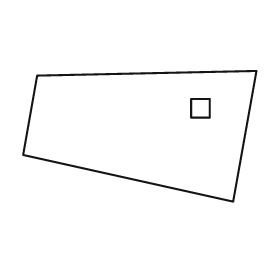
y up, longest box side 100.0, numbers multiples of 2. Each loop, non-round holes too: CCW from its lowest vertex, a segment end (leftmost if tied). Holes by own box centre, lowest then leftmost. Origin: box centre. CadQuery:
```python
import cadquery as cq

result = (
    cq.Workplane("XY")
    .moveTo(40.0, -28.0)
    .lineTo(50.0, 28.0)
    .lineTo(-44.0, 26.0)
    .lineTo(-50.0, -8.0)
    .close()
    .moveTo(22.0, 8.0)
    .lineTo(30.0, 8.0)
    .lineTo(30.0, 16.0)
    .lineTo(22.0, 16.0)
    .close()
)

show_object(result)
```